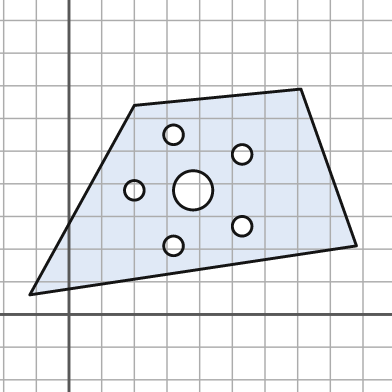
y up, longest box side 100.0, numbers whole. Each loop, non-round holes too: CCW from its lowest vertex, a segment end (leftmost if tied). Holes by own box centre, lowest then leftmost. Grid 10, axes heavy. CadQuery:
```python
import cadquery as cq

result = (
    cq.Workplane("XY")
    .moveTo(-12.0, 6.0)
    .lineTo(88.0, 21.0)
    .lineTo(71.0, 69.0)
    .lineTo(20.0, 64.0)
    .close()
    .moveTo(32.0, 21.0)
    .circle(3.0)
    .moveTo(53.0, 27.0)
    .circle(3.0)
    .moveTo(20.0, 38.0)
    .circle(3.0)
    .moveTo(38.0, 38.0)
    .circle(6.0)
    .moveTo(53.0, 49.0)
    .circle(3.0)
    .moveTo(32.0, 55.0)
    .circle(3.0)
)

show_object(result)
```